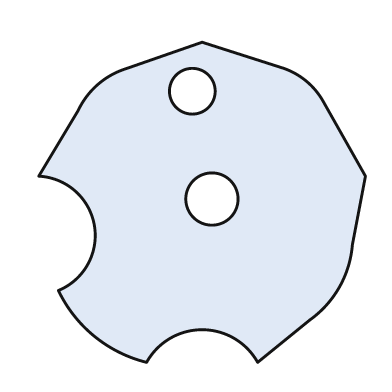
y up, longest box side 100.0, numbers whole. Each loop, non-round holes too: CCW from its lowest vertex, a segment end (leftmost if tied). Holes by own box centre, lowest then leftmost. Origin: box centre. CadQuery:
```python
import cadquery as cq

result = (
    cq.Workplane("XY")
    .moveTo(-17.0, -49.0)
    .threePointArc((0.0, -39.0), (17.0, -49.0))
    .lineTo(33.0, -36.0)
    .threePointArc((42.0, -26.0), (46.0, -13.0))
    .lineTo(50.0, 8.0)
    .lineTo(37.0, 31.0)
    .threePointArc((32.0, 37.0), (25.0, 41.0))
    .lineTo(0.0, 49.0)
    .lineTo(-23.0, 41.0)
    .threePointArc((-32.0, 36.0), (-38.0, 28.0))
    .lineTo(-50.0, 8.0)
    .threePointArc((-33.0, -7.0), (-44.0, -27.0))
    .threePointArc((-33.0, -41.0), (-17.0, -49.0))
    .close()
    .moveTo(3.0, 1.0)
    .circle(8.0)
    .moveTo(-3.0, 34.0)
    .circle(7.0)
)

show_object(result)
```